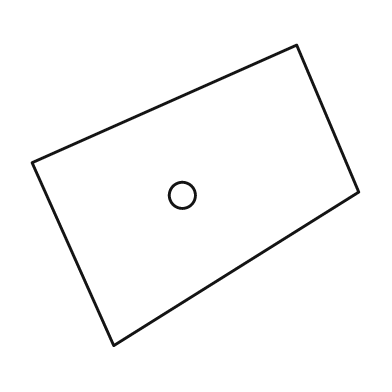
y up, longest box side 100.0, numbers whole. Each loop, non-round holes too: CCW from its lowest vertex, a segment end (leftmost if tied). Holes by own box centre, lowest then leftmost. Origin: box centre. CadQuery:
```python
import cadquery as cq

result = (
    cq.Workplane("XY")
    .moveTo(-25.0, -46.0)
    .lineTo(50.0, 1.0)
    .lineTo(31.0, 46.0)
    .lineTo(-50.0, 10.0)
    .close()
    .moveTo(-4.0, 0.0)
    .circle(4.0)
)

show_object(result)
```